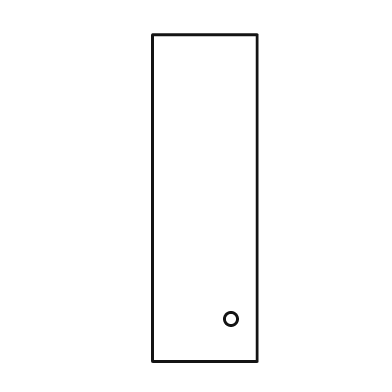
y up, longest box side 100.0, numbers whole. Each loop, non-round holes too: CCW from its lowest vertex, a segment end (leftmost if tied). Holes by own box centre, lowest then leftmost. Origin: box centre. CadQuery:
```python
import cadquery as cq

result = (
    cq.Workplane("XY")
    .moveTo(-16.0, -50.0)
    .lineTo(16.0, -50.0)
    .lineTo(16.0, 50.0)
    .lineTo(-16.0, 50.0)
    .close()
    .moveTo(8.0, -37.0)
    .circle(2.0)
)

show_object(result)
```